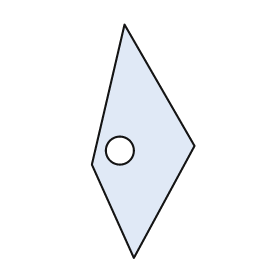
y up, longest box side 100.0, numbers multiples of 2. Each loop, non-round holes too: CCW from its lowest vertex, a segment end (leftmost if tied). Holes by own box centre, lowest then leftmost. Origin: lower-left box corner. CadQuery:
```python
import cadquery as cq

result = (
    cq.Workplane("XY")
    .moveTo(18.0, 0.0)
    .lineTo(44.0, 48.0)
    .lineTo(14.0, 100.0)
    .lineTo(0.0, 40.0)
    .close()
    .moveTo(12.0, 46.0)
    .circle(6.0)
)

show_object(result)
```